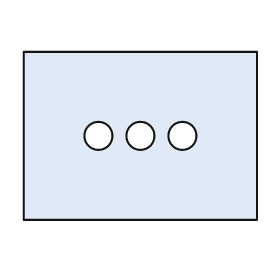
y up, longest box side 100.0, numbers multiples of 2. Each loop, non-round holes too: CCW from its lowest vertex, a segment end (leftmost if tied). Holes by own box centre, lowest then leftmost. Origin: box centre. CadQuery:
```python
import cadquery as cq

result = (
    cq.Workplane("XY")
    .moveTo(-50.0, -36.0)
    .lineTo(50.0, -36.0)
    .lineTo(50.0, 36.0)
    .lineTo(-50.0, 36.0)
    .close()
    .moveTo(-18.0, 0.0)
    .circle(6.0)
    .moveTo(0.0, 0.0)
    .circle(6.0)
    .moveTo(18.0, 0.0)
    .circle(6.0)
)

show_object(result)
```